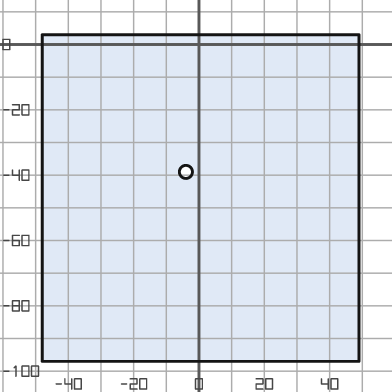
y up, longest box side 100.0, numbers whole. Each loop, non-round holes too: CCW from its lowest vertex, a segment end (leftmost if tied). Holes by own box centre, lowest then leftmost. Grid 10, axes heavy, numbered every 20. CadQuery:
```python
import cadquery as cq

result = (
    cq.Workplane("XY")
    .moveTo(-48.0, -97.0)
    .lineTo(49.0, -97.0)
    .lineTo(49.0, 3.0)
    .lineTo(-48.0, 3.0)
    .close()
    .moveTo(-4.0, -39.0)
    .circle(2.0)
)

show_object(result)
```